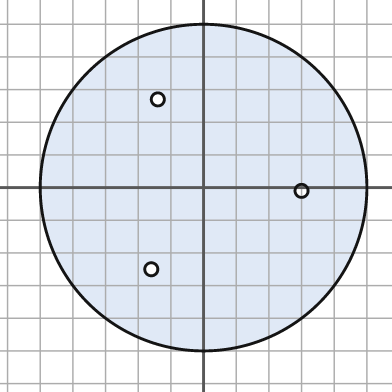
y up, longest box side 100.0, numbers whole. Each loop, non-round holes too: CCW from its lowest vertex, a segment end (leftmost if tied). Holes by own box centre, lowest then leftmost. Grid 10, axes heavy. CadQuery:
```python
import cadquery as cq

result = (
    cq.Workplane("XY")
    .moveTo(0.0, 0.0)
    .circle(50.0)
    .moveTo(-16.0, -25.0)
    .circle(2.0)
    .moveTo(30.0, -1.0)
    .circle(2.0)
    .moveTo(-14.0, 27.0)
    .circle(2.0)
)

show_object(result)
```